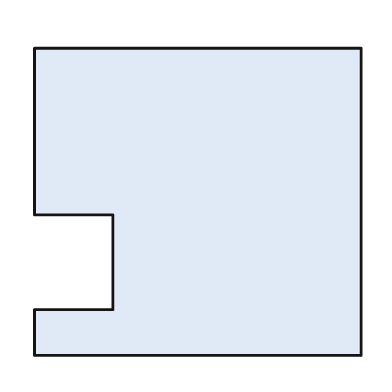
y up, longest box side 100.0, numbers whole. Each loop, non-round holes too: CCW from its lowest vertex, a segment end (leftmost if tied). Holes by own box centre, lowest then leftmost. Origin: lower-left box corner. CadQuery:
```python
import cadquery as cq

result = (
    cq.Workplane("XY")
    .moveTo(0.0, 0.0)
    .lineTo(100.0, 0.0)
    .lineTo(100.0, 94.0)
    .lineTo(0.0, 94.0)
    .lineTo(0.0, 43.0)
    .lineTo(24.0, 43.0)
    .lineTo(24.0, 14.0)
    .lineTo(0.0, 14.0)
    .close()
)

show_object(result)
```